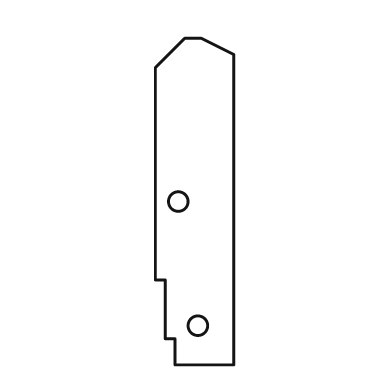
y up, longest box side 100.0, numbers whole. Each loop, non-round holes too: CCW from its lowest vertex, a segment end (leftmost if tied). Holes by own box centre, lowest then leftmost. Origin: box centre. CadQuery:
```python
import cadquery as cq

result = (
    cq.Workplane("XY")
    .moveTo(-6.0, -50.0)
    .lineTo(12.0, -50.0)
    .lineTo(12.0, 45.0)
    .lineTo(2.0, 50.0)
    .lineTo(-3.0, 50.0)
    .lineTo(-12.0, 41.0)
    .lineTo(-12.0, -24.0)
    .lineTo(-9.0, -24.0)
    .lineTo(-9.0, -42.0)
    .lineTo(-6.0, -42.0)
    .close()
    .moveTo(1.0, -38.0)
    .circle(3.0)
    .moveTo(-5.0, 0.0)
    .circle(3.0)
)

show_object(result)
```